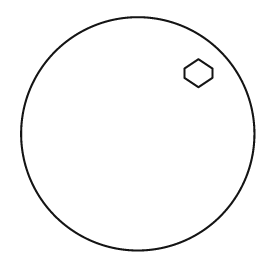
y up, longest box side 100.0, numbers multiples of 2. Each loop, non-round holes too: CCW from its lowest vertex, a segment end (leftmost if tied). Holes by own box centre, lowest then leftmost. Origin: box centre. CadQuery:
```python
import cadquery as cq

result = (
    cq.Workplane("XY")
    .moveTo(0.0, 0.0)
    .circle(50.0)
    .moveTo(26.0, 20.0)
    .lineTo(32.0, 24.0)
    .lineTo(32.0, 28.0)
    .lineTo(26.0, 32.0)
    .lineTo(20.0, 28.0)
    .lineTo(20.0, 24.0)
    .close()
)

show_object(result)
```